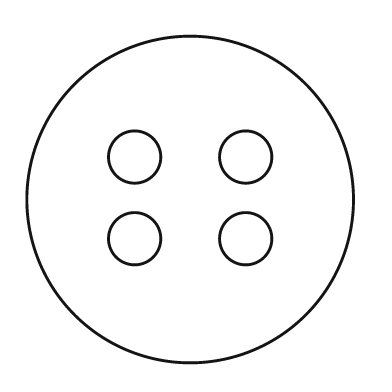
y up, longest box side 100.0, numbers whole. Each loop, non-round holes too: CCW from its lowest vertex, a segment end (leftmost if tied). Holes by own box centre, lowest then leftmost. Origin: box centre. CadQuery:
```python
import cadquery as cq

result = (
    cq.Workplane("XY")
    .moveTo(0.0, 0.0)
    .circle(50.0)
    .moveTo(-17.0, -12.0)
    .circle(8.0)
    .moveTo(17.0, -12.0)
    .circle(8.0)
    .moveTo(-17.0, 13.0)
    .circle(8.0)
    .moveTo(17.0, 13.0)
    .circle(8.0)
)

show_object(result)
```